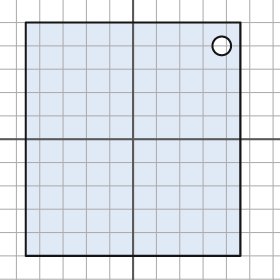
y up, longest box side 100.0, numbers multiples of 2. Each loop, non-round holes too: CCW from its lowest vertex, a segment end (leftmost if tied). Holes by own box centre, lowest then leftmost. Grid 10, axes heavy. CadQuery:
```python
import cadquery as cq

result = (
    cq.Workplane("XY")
    .moveTo(-46.0, -50.0)
    .lineTo(46.0, -50.0)
    .lineTo(46.0, 50.0)
    .lineTo(-46.0, 50.0)
    .close()
    .moveTo(38.0, 40.0)
    .circle(4.0)
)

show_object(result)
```